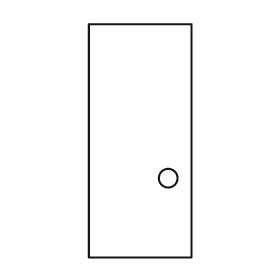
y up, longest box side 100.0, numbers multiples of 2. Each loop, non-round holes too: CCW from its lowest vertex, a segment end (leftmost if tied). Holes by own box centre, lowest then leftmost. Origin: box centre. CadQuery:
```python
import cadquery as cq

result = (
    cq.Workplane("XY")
    .moveTo(-22.0, -50.0)
    .lineTo(22.0, -50.0)
    .lineTo(22.0, 50.0)
    .lineTo(-22.0, 50.0)
    .close()
    .moveTo(12.0, -16.0)
    .circle(4.0)
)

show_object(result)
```